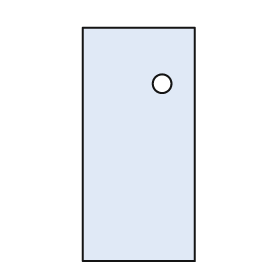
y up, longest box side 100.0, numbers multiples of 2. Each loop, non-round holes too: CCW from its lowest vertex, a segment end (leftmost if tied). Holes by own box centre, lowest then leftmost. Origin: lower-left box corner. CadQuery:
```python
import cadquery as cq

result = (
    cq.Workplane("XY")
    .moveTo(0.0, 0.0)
    .lineTo(48.0, 0.0)
    .lineTo(48.0, 100.0)
    .lineTo(0.0, 100.0)
    .close()
    .moveTo(34.0, 76.0)
    .circle(4.0)
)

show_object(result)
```